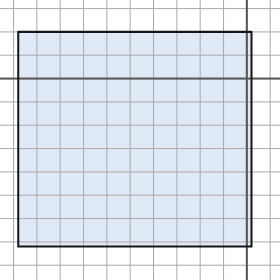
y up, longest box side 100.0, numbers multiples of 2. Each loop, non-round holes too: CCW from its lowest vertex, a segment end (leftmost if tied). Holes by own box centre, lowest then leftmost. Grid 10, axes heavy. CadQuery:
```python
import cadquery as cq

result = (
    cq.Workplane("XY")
    .moveTo(-98.0, -72.0)
    .lineTo(2.0, -72.0)
    .lineTo(2.0, 20.0)
    .lineTo(-98.0, 20.0)
    .close()
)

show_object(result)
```